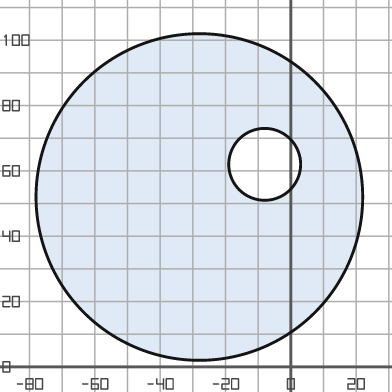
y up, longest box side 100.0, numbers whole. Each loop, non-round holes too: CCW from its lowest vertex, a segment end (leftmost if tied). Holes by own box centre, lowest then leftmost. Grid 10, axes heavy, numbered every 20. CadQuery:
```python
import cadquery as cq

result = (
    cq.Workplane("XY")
    .moveTo(-28.0, 52.0)
    .circle(50.0)
    .moveTo(-8.0, 62.0)
    .circle(11.0)
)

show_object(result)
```